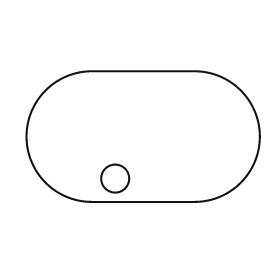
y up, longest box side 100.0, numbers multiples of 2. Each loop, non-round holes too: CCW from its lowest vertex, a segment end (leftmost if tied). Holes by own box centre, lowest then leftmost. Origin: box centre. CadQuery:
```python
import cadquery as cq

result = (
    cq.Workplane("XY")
    .moveTo(-22.0, -28.0)
    .lineTo(22.0, -28.0)
    .threePointArc((50.0, 0.0), (22.0, 28.0))
    .lineTo(-22.0, 28.0)
    .threePointArc((-50.0, 0.0), (-22.0, -28.0))
    .close()
    .moveTo(-12.0, -18.0)
    .circle(6.0)
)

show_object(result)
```